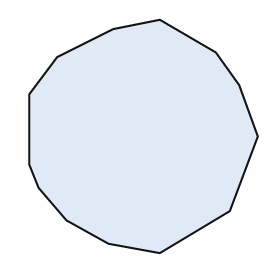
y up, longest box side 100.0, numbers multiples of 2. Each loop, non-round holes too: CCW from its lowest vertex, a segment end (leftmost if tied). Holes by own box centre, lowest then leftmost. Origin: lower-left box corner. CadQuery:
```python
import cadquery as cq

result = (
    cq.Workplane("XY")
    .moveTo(56.0, 0.0)
    .lineTo(86.0, 18.0)
    .lineTo(98.0, 50.0)
    .lineTo(90.0, 72.0)
    .lineTo(80.0, 86.0)
    .lineTo(56.0, 100.0)
    .lineTo(36.0, 96.0)
    .lineTo(12.0, 84.0)
    .lineTo(0.0, 68.0)
    .lineTo(0.0, 38.0)
    .lineTo(4.0, 28.0)
    .lineTo(16.0, 14.0)
    .lineTo(34.0, 4.0)
    .close()
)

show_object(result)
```